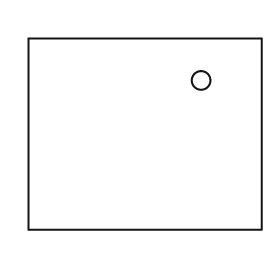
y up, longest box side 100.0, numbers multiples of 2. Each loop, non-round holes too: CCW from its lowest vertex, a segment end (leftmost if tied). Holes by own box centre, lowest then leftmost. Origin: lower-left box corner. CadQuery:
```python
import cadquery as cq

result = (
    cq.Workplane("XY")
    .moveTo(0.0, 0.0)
    .lineTo(100.0, 0.0)
    .lineTo(100.0, 82.0)
    .lineTo(0.0, 82.0)
    .close()
    .moveTo(74.0, 64.0)
    .circle(4.0)
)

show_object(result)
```